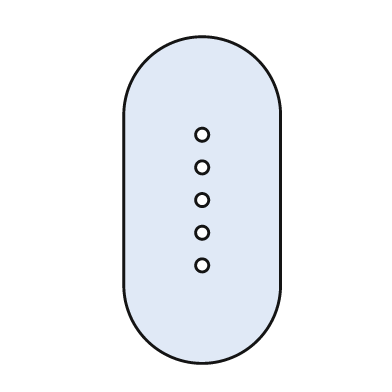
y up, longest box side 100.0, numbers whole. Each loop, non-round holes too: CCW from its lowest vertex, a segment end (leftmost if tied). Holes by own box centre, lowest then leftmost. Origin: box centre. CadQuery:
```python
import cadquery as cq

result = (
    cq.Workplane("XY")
    .moveTo(-24.0, -26.0)
    .threePointArc((0.0, -50.0), (24.0, -26.0))
    .lineTo(24.0, 26.0)
    .threePointArc((0.0, 50.0), (-24.0, 26.0))
    .close()
    .moveTo(0.0, -20.0)
    .circle(2.0)
    .moveTo(0.0, -10.0)
    .circle(2.0)
    .moveTo(0.0, 0.0)
    .circle(2.0)
    .moveTo(0.0, 10.0)
    .circle(2.0)
    .moveTo(0.0, 20.0)
    .circle(2.0)
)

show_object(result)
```